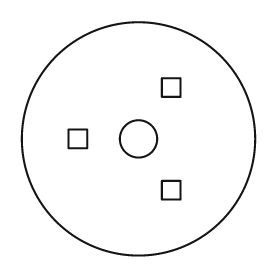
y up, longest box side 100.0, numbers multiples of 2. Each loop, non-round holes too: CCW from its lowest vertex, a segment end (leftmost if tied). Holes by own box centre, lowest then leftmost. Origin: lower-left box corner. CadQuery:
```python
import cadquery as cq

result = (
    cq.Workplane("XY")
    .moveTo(50.0, 50.0)
    .circle(50.0)
    .moveTo(60.0, 24.0)
    .lineTo(68.0, 24.0)
    .lineTo(68.0, 32.0)
    .lineTo(60.0, 32.0)
    .close()
    .moveTo(20.0, 46.0)
    .lineTo(28.0, 46.0)
    .lineTo(28.0, 54.0)
    .lineTo(20.0, 54.0)
    .close()
    .moveTo(50.0, 50.0)
    .circle(8.0)
    .moveTo(60.0, 68.0)
    .lineTo(68.0, 68.0)
    .lineTo(68.0, 76.0)
    .lineTo(60.0, 76.0)
    .close()
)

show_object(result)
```